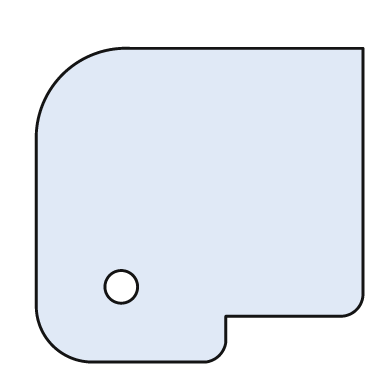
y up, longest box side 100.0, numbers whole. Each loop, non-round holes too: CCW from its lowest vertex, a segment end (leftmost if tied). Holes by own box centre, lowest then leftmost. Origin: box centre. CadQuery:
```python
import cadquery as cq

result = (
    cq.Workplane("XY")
    .moveTo(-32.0, -48.0)
    .lineTo(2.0, -48.0)
    .threePointArc((6.0, -46.0), (8.0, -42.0))
    .lineTo(8.0, -34.0)
    .lineTo(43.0, -34.0)
    .threePointArc((48.0, -32.0), (50.0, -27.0))
    .lineTo(50.0, 48.0)
    .lineTo(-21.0, 48.0)
    .threePointArc((-42.0, 40.0), (-50.0, 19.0))
    .lineTo(-50.0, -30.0)
    .threePointArc((-45.0, -43.0), (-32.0, -48.0))
    .close()
    .moveTo(-24.0, -25.0)
    .circle(5.0)
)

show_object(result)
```